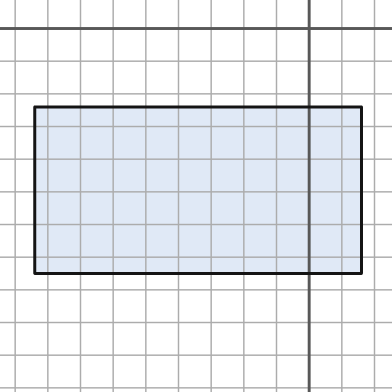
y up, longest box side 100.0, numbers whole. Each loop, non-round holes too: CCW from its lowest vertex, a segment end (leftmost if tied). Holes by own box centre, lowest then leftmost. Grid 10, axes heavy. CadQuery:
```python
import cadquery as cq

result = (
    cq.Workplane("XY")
    .moveTo(-84.0, -75.0)
    .lineTo(16.0, -75.0)
    .lineTo(16.0, -24.0)
    .lineTo(-84.0, -24.0)
    .close()
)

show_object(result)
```